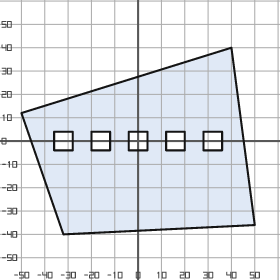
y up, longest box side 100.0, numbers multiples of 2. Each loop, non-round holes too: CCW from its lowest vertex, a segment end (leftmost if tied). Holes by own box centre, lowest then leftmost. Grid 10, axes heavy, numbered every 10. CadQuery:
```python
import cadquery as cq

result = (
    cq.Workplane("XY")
    .moveTo(-32.0, -40.0)
    .lineTo(50.0, -36.0)
    .lineTo(40.0, 40.0)
    .lineTo(-50.0, 12.0)
    .close()
    .moveTo(-36.0, -4.0)
    .lineTo(-28.0, -4.0)
    .lineTo(-28.0, 4.0)
    .lineTo(-36.0, 4.0)
    .close()
    .moveTo(-20.0, -4.0)
    .lineTo(-12.0, -4.0)
    .lineTo(-12.0, 4.0)
    .lineTo(-20.0, 4.0)
    .close()
    .moveTo(-4.0, -4.0)
    .lineTo(4.0, -4.0)
    .lineTo(4.0, 4.0)
    .lineTo(-4.0, 4.0)
    .close()
    .moveTo(12.0, -4.0)
    .lineTo(20.0, -4.0)
    .lineTo(20.0, 4.0)
    .lineTo(12.0, 4.0)
    .close()
    .moveTo(28.0, -4.0)
    .lineTo(36.0, -4.0)
    .lineTo(36.0, 4.0)
    .lineTo(28.0, 4.0)
    .close()
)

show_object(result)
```